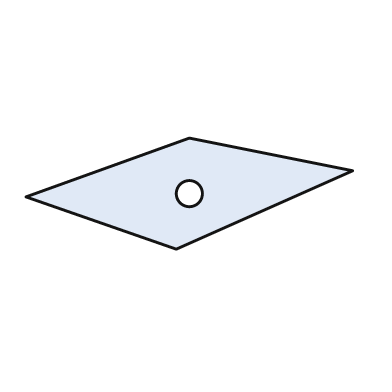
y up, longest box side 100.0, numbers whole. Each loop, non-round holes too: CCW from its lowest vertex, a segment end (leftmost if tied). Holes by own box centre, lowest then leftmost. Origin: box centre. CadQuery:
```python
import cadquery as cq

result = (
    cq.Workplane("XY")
    .moveTo(-4.0, -17.0)
    .lineTo(50.0, 7.0)
    .lineTo(0.0, 17.0)
    .lineTo(-50.0, -1.0)
    .close()
    .moveTo(0.0, 0.0)
    .circle(4.0)
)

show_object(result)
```